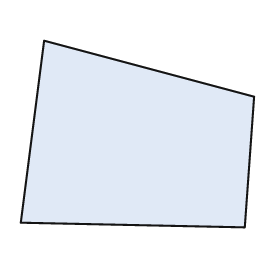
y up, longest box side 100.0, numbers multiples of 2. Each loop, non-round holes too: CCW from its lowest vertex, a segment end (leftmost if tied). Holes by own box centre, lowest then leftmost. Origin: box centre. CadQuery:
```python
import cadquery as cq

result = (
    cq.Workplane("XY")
    .moveTo(46.0, -40.0)
    .lineTo(50.0, 16.0)
    .lineTo(-40.0, 40.0)
    .lineTo(-50.0, -38.0)
    .close()
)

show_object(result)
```